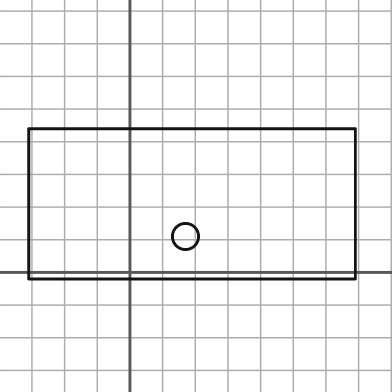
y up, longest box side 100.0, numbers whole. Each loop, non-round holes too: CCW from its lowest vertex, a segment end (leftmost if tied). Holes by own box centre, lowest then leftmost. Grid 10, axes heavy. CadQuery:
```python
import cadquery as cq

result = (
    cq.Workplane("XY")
    .moveTo(-31.0, -2.0)
    .lineTo(69.0, -2.0)
    .lineTo(69.0, 44.0)
    .lineTo(-31.0, 44.0)
    .close()
    .moveTo(17.0, 11.0)
    .circle(4.0)
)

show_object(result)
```